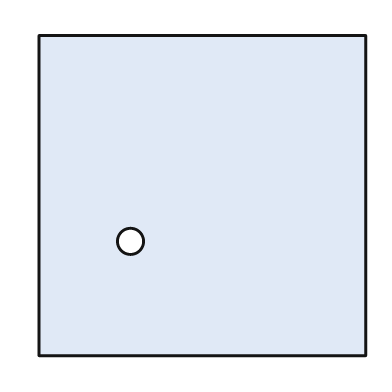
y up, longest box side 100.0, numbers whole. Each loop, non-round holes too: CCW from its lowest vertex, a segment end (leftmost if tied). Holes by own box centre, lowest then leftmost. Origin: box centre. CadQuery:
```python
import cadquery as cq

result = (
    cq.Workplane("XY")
    .moveTo(-50.0, -49.0)
    .lineTo(50.0, -49.0)
    .lineTo(50.0, 49.0)
    .lineTo(-50.0, 49.0)
    .close()
    .moveTo(-22.0, -14.0)
    .circle(4.0)
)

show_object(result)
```